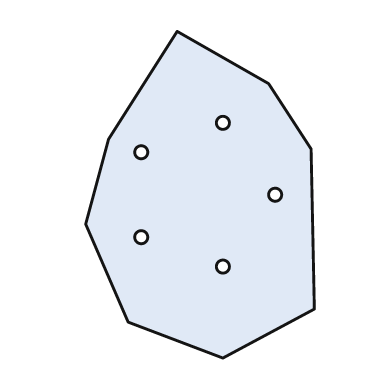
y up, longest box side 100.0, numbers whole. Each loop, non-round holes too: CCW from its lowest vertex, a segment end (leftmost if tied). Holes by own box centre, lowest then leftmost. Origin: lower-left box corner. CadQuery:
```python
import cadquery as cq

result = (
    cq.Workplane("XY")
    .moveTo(42.0, 0.0)
    .lineTo(70.0, 15.0)
    .lineTo(69.0, 64.0)
    .lineTo(56.0, 84.0)
    .lineTo(28.0, 100.0)
    .lineTo(7.0, 67.0)
    .lineTo(0.0, 41.0)
    .lineTo(13.0, 11.0)
    .close()
    .moveTo(42.0, 28.0)
    .circle(2.0)
    .moveTo(17.0, 37.0)
    .circle(2.0)
    .moveTo(58.0, 50.0)
    .circle(2.0)
    .moveTo(17.0, 63.0)
    .circle(2.0)
    .moveTo(42.0, 72.0)
    .circle(2.0)
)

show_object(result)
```